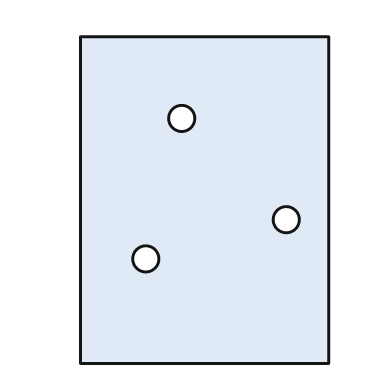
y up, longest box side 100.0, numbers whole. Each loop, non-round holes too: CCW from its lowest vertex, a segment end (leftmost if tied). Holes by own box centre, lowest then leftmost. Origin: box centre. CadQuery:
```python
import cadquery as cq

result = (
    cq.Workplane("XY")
    .moveTo(-38.0, -50.0)
    .lineTo(38.0, -50.0)
    .lineTo(38.0, 50.0)
    .lineTo(-38.0, 50.0)
    .close()
    .moveTo(-18.0, -18.0)
    .circle(4.0)
    .moveTo(25.0, -6.0)
    .circle(4.0)
    .moveTo(-7.0, 25.0)
    .circle(4.0)
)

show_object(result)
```